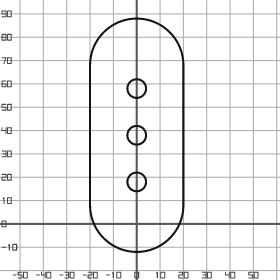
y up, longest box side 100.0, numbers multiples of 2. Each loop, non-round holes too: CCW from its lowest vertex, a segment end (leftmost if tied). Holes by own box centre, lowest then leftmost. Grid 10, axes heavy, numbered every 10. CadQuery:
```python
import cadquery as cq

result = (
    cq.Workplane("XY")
    .moveTo(-20.0, 8.0)
    .threePointArc((0.0, -12.0), (20.0, 8.0))
    .lineTo(20.0, 68.0)
    .threePointArc((0.0, 88.0), (-20.0, 68.0))
    .close()
    .moveTo(0.0, 18.0)
    .circle(4.0)
    .moveTo(0.0, 38.0)
    .circle(4.0)
    .moveTo(0.0, 58.0)
    .circle(4.0)
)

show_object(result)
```